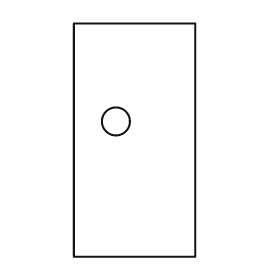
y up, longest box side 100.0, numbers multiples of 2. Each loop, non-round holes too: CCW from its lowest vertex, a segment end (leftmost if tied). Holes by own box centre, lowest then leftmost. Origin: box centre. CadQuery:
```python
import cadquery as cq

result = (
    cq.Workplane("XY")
    .moveTo(-26.0, -50.0)
    .lineTo(26.0, -50.0)
    .lineTo(26.0, 50.0)
    .lineTo(-26.0, 50.0)
    .close()
    .moveTo(-8.0, 8.0)
    .circle(6.0)
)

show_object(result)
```